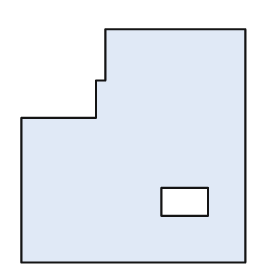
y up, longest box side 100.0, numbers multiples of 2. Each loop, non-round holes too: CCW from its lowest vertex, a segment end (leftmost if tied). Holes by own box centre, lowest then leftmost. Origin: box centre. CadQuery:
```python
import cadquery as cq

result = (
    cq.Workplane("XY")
    .moveTo(-48.0, -50.0)
    .lineTo(48.0, -50.0)
    .lineTo(48.0, 50.0)
    .lineTo(-12.0, 50.0)
    .lineTo(-12.0, 28.0)
    .lineTo(-16.0, 28.0)
    .lineTo(-16.0, 12.0)
    .lineTo(-48.0, 12.0)
    .close()
    .moveTo(12.0, -30.0)
    .lineTo(32.0, -30.0)
    .lineTo(32.0, -18.0)
    .lineTo(12.0, -18.0)
    .close()
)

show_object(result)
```